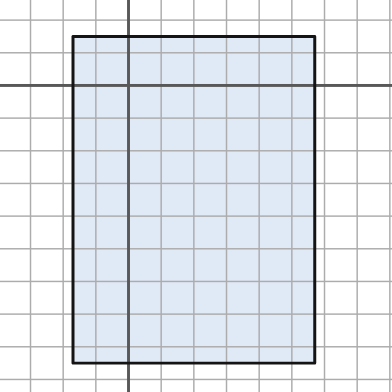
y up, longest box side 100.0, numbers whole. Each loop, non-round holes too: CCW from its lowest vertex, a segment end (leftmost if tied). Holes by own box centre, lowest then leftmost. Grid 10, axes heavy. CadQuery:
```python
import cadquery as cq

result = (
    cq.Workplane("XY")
    .moveTo(-17.0, -85.0)
    .lineTo(57.0, -85.0)
    .lineTo(57.0, 15.0)
    .lineTo(-17.0, 15.0)
    .close()
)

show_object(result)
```